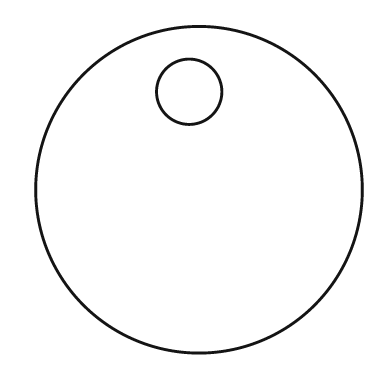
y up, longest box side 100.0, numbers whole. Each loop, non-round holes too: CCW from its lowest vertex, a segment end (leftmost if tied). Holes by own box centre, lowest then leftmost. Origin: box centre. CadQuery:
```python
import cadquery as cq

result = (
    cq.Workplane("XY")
    .moveTo(0.0, 0.0)
    .circle(50.0)
    .moveTo(-3.0, 30.0)
    .circle(10.0)
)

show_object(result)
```